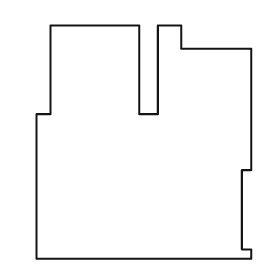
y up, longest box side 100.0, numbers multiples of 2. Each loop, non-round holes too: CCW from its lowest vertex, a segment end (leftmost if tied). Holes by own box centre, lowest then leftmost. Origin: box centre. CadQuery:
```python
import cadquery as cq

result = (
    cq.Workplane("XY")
    .moveTo(-46.0, -50.0)
    .lineTo(46.0, -50.0)
    .lineTo(46.0, -46.0)
    .lineTo(42.0, -46.0)
    .lineTo(42.0, -12.0)
    .lineTo(46.0, -12.0)
    .lineTo(46.0, 40.0)
    .lineTo(16.0, 40.0)
    .lineTo(16.0, 50.0)
    .lineTo(6.0, 50.0)
    .lineTo(6.0, 12.0)
    .lineTo(-2.0, 12.0)
    .lineTo(-2.0, 50.0)
    .lineTo(-40.0, 50.0)
    .lineTo(-40.0, 12.0)
    .lineTo(-46.0, 12.0)
    .close()
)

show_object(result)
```